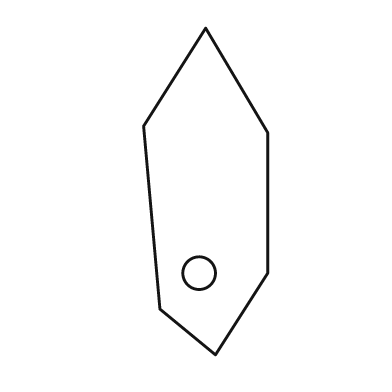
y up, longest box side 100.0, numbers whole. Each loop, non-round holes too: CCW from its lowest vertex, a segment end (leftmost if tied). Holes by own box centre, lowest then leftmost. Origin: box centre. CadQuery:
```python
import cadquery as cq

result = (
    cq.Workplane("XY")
    .moveTo(3.0, -50.0)
    .lineTo(19.0, -25.0)
    .lineTo(19.0, 18.0)
    .lineTo(0.0, 50.0)
    .lineTo(-19.0, 20.0)
    .lineTo(-14.0, -36.0)
    .close()
    .moveTo(-2.0, -25.0)
    .circle(5.0)
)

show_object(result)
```